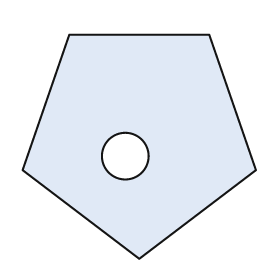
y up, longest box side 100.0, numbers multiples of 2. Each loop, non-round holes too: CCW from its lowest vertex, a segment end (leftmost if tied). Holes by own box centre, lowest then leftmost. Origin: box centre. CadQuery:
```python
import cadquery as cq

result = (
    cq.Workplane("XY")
    .moveTo(0.0, -48.0)
    .lineTo(50.0, -10.0)
    .lineTo(30.0, 48.0)
    .lineTo(-30.0, 48.0)
    .lineTo(-50.0, -10.0)
    .close()
    .moveTo(-6.0, -4.0)
    .circle(10.0)
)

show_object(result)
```